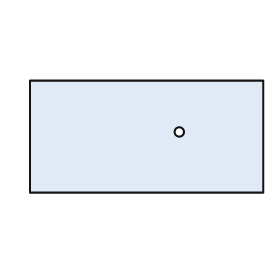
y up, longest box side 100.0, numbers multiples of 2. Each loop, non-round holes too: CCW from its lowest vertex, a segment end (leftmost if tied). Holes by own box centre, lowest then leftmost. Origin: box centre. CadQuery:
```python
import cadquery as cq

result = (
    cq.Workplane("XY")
    .moveTo(-50.0, -24.0)
    .lineTo(50.0, -24.0)
    .lineTo(50.0, 24.0)
    .lineTo(-50.0, 24.0)
    .close()
    .moveTo(14.0, 2.0)
    .circle(2.0)
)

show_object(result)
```